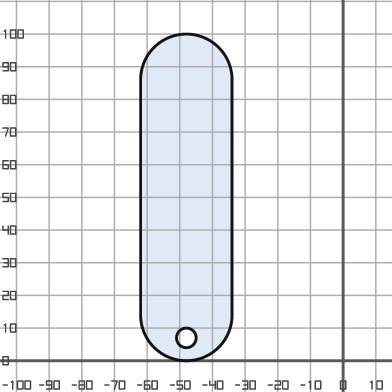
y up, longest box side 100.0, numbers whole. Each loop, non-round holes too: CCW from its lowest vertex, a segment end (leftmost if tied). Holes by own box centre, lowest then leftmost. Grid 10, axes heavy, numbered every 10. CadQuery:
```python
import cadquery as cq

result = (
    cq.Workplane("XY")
    .moveTo(-62.0, 14.0)
    .threePointArc((-48.0, 0.0), (-34.0, 14.0))
    .lineTo(-34.0, 86.0)
    .threePointArc((-48.0, 100.0), (-62.0, 86.0))
    .close()
    .moveTo(-48.0, 7.0)
    .circle(3.0)
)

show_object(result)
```